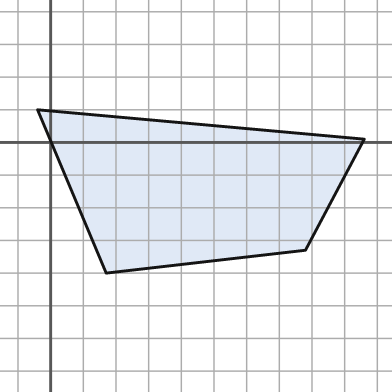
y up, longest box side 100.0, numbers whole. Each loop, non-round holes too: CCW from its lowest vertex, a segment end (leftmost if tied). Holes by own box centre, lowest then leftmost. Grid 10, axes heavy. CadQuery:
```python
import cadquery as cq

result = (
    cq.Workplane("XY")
    .moveTo(17.0, -40.0)
    .lineTo(78.0, -33.0)
    .lineTo(96.0, 1.0)
    .lineTo(-4.0, 10.0)
    .close()
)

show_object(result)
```